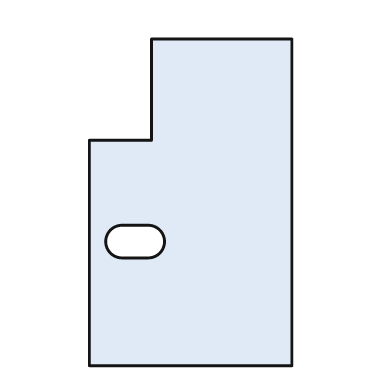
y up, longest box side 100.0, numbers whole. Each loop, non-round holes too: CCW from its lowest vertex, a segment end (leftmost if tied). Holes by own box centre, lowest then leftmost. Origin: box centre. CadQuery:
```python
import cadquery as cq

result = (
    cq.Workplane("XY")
    .moveTo(-31.0, -50.0)
    .lineTo(31.0, -50.0)
    .lineTo(31.0, 50.0)
    .lineTo(-12.0, 50.0)
    .lineTo(-12.0, 19.0)
    .lineTo(-31.0, 19.0)
    .close()
    .moveTo(-21.0, -17.0)
    .lineTo(-13.0, -17.0)
    .threePointArc((-8.0, -12.0), (-13.0, -7.0))
    .lineTo(-21.0, -7.0)
    .threePointArc((-26.0, -12.0), (-21.0, -17.0))
    .close()
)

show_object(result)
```